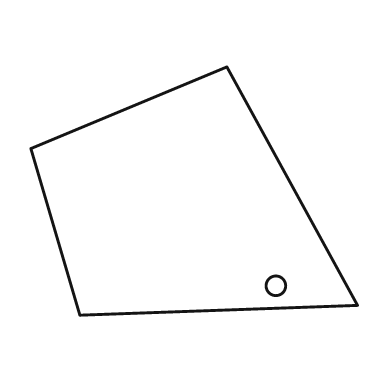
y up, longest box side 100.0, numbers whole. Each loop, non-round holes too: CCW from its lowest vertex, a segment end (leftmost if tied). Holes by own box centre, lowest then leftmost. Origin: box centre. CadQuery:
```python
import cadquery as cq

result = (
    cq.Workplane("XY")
    .moveTo(-35.0, -38.0)
    .lineTo(50.0, -35.0)
    .lineTo(10.0, 38.0)
    .lineTo(-50.0, 13.0)
    .close()
    .moveTo(25.0, -29.0)
    .circle(3.0)
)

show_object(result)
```